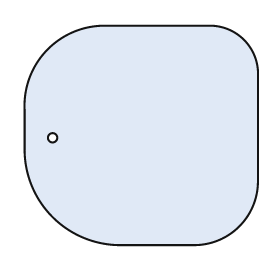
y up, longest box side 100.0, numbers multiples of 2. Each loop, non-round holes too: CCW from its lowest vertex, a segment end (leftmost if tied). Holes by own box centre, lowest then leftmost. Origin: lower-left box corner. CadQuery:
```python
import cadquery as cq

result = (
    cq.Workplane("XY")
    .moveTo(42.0, 0.0)
    .lineTo(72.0, 0.0)
    .threePointArc((92.0, 8.0), (100.0, 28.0))
    .lineTo(100.0, 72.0)
    .threePointArc((94.0, 88.0), (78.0, 94.0))
    .lineTo(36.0, 94.0)
    .threePointArc((10.0, 84.0), (0.0, 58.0))
    .lineTo(0.0, 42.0)
    .threePointArc((12.0, 12.0), (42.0, 0.0))
    .close()
    .moveTo(12.0, 46.0)
    .circle(2.0)
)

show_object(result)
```